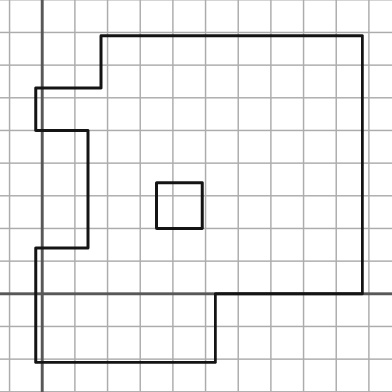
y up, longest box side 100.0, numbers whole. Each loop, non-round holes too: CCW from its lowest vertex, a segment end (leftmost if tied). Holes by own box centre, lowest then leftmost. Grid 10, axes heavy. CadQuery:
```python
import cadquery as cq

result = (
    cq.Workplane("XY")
    .moveTo(-2.0, -21.0)
    .lineTo(53.0, -21.0)
    .lineTo(53.0, 0.0)
    .lineTo(98.0, 0.0)
    .lineTo(98.0, 79.0)
    .lineTo(18.0, 79.0)
    .lineTo(18.0, 63.0)
    .lineTo(-2.0, 63.0)
    .lineTo(-2.0, 50.0)
    .lineTo(14.0, 50.0)
    .lineTo(14.0, 14.0)
    .lineTo(-2.0, 14.0)
    .close()
    .moveTo(35.0, 20.0)
    .lineTo(49.0, 20.0)
    .lineTo(49.0, 34.0)
    .lineTo(35.0, 34.0)
    .close()
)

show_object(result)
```